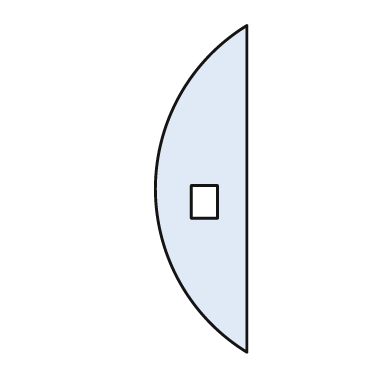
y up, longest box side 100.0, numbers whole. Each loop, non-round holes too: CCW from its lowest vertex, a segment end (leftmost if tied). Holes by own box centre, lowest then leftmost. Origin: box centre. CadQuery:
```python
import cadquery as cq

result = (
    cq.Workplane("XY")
    .moveTo(14.0, -50.0)
    .lineTo(14.0, 50.0)
    .threePointArc((-14.0, 0.0), (14.0, -50.0))
    .close()
    .moveTo(-3.0, -9.0)
    .lineTo(5.0, -9.0)
    .lineTo(5.0, 1.0)
    .lineTo(-3.0, 1.0)
    .close()
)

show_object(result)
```